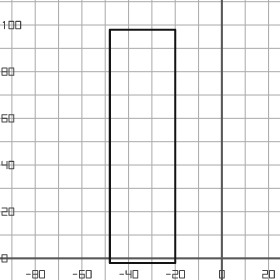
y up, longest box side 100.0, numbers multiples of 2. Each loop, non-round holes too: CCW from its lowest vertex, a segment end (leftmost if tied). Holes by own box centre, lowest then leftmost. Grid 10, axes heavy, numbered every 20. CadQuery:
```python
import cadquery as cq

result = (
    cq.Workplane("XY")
    .moveTo(-48.0, -2.0)
    .lineTo(-20.0, -2.0)
    .lineTo(-20.0, 98.0)
    .lineTo(-48.0, 98.0)
    .close()
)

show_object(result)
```